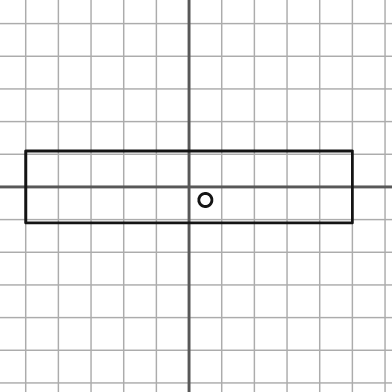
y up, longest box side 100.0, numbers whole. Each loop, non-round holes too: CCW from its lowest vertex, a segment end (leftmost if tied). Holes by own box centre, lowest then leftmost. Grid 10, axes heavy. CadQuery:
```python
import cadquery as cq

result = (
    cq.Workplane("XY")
    .moveTo(-50.0, -11.0)
    .lineTo(50.0, -11.0)
    .lineTo(50.0, 11.0)
    .lineTo(-50.0, 11.0)
    .close()
    .moveTo(5.0, -4.0)
    .circle(2.0)
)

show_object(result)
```